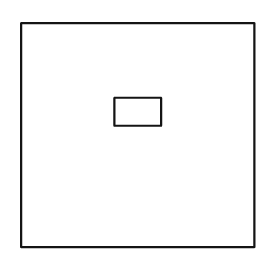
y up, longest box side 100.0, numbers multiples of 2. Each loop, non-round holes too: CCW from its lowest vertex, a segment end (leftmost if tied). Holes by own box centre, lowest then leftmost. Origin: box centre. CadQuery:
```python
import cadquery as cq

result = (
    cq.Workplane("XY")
    .moveTo(-50.0, -48.0)
    .lineTo(50.0, -48.0)
    .lineTo(50.0, 48.0)
    .lineTo(-50.0, 48.0)
    .close()
    .moveTo(-10.0, 4.0)
    .lineTo(10.0, 4.0)
    .lineTo(10.0, 16.0)
    .lineTo(-10.0, 16.0)
    .close()
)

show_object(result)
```